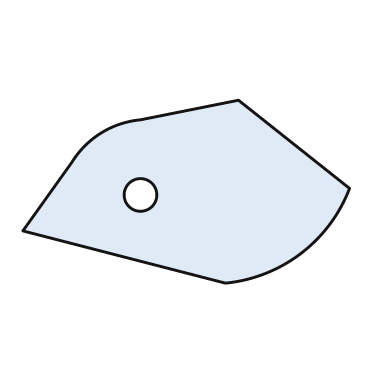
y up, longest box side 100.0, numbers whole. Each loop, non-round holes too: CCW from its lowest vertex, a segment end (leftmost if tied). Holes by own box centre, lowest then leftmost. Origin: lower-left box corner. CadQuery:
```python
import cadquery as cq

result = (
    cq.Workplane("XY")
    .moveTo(62.0, 0.0)
    .threePointArc((85.0, 9.0), (100.0, 29.0))
    .lineTo(66.0, 56.0)
    .lineTo(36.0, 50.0)
    .threePointArc((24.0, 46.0), (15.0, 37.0))
    .lineTo(0.0, 16.0)
    .close()
    .moveTo(36.0, 27.0)
    .circle(5.0)
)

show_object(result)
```